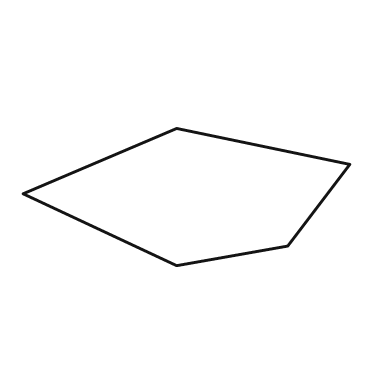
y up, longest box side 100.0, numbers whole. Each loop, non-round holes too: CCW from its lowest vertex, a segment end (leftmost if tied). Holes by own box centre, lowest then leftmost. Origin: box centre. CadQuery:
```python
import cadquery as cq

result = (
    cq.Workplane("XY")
    .moveTo(-3.0, -21.0)
    .lineTo(31.0, -15.0)
    .lineTo(50.0, 10.0)
    .lineTo(-3.0, 21.0)
    .lineTo(-50.0, 1.0)
    .close()
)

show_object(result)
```